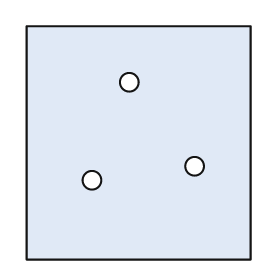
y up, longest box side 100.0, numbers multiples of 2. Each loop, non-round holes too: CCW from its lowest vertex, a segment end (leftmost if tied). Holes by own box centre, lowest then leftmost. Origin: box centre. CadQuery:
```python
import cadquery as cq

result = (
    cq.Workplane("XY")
    .moveTo(-48.0, -50.0)
    .lineTo(48.0, -50.0)
    .lineTo(48.0, 50.0)
    .lineTo(-48.0, 50.0)
    .close()
    .moveTo(-20.0, -16.0)
    .circle(4.0)
    .moveTo(24.0, -10.0)
    .circle(4.0)
    .moveTo(-4.0, 26.0)
    .circle(4.0)
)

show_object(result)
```